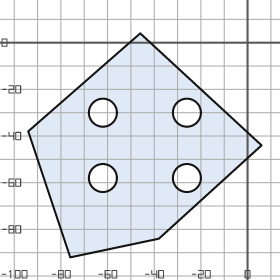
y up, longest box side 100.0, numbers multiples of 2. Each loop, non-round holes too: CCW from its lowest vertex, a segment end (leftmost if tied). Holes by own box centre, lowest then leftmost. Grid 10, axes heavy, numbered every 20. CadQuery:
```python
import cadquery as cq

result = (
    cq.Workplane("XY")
    .moveTo(-76.0, -92.0)
    .lineTo(-38.0, -84.0)
    .lineTo(6.0, -44.0)
    .lineTo(-46.0, 4.0)
    .lineTo(-94.0, -38.0)
    .close()
    .moveTo(-62.0, -58.0)
    .circle(6.0)
    .moveTo(-26.0, -58.0)
    .circle(6.0)
    .moveTo(-62.0, -30.0)
    .circle(6.0)
    .moveTo(-26.0, -30.0)
    .circle(6.0)
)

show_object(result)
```